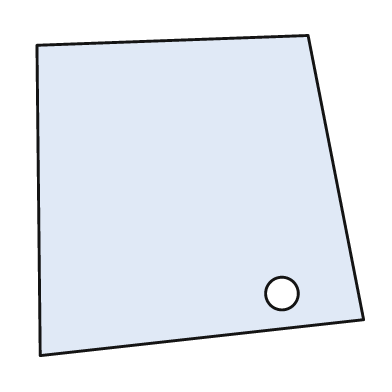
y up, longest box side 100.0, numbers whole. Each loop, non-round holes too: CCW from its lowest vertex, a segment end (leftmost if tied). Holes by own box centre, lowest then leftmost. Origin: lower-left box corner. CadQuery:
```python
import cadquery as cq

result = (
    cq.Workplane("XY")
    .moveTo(1.0, 0.0)
    .lineTo(100.0, 11.0)
    .lineTo(83.0, 98.0)
    .lineTo(0.0, 95.0)
    .close()
    .moveTo(75.0, 19.0)
    .circle(5.0)
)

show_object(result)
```